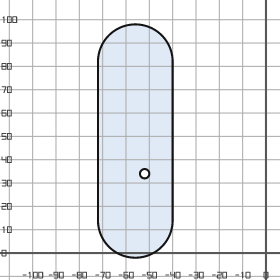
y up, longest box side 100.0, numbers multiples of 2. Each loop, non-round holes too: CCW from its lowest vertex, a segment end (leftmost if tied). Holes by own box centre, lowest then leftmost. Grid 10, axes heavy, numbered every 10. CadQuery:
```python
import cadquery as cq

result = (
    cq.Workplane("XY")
    .moveTo(-72.0, 14.0)
    .threePointArc((-56.0, -2.0), (-40.0, 14.0))
    .lineTo(-40.0, 82.0)
    .threePointArc((-56.0, 98.0), (-72.0, 82.0))
    .close()
    .moveTo(-52.0, 34.0)
    .circle(2.0)
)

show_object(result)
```